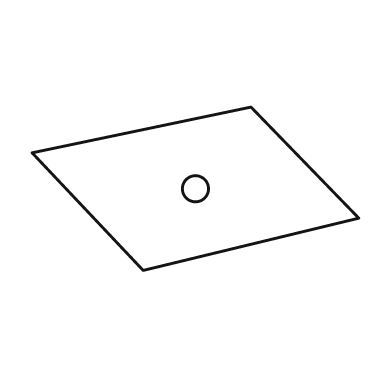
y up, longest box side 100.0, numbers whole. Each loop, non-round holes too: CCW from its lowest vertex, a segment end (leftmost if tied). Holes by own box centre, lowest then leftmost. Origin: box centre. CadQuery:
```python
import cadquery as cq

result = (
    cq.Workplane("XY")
    .moveTo(-16.0, -25.0)
    .lineTo(50.0, -9.0)
    .lineTo(17.0, 25.0)
    .lineTo(-50.0, 11.0)
    .close()
    .moveTo(0.0, 0.0)
    .circle(4.0)
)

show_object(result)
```